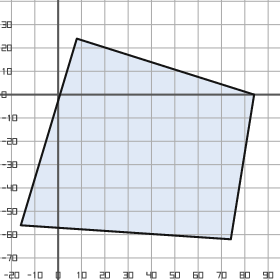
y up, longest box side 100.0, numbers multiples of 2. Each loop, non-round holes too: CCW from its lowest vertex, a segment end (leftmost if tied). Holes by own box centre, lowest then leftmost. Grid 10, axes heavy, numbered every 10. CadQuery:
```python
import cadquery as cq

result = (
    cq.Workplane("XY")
    .moveTo(74.0, -62.0)
    .lineTo(84.0, 0.0)
    .lineTo(8.0, 24.0)
    .lineTo(-16.0, -56.0)
    .close()
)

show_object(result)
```